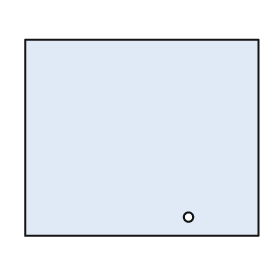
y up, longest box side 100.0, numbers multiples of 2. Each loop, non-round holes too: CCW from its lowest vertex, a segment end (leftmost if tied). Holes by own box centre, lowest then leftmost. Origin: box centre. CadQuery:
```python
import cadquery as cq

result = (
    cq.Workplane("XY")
    .moveTo(-50.0, -42.0)
    .lineTo(50.0, -42.0)
    .lineTo(50.0, 42.0)
    .lineTo(-50.0, 42.0)
    .close()
    .moveTo(20.0, -34.0)
    .circle(2.0)
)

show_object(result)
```